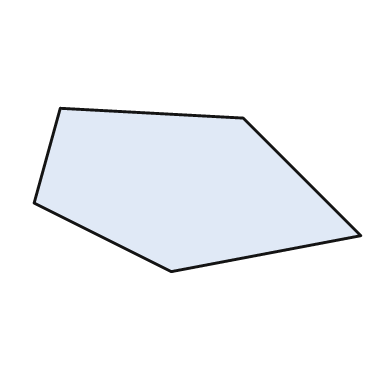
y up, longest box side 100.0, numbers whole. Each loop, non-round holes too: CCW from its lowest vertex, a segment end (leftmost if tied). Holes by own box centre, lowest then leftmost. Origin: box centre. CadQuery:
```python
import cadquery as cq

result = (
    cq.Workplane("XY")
    .moveTo(-8.0, -25.0)
    .lineTo(50.0, -14.0)
    .lineTo(14.0, 22.0)
    .lineTo(-42.0, 25.0)
    .lineTo(-50.0, -4.0)
    .close()
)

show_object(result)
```